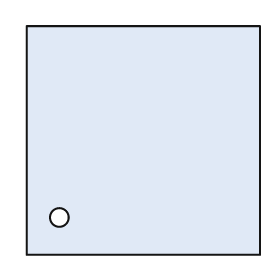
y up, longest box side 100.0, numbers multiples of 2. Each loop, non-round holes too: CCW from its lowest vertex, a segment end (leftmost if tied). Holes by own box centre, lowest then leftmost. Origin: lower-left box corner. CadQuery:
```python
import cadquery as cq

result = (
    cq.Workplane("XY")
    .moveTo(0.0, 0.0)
    .lineTo(100.0, 0.0)
    .lineTo(100.0, 98.0)
    .lineTo(0.0, 98.0)
    .close()
    .moveTo(14.0, 16.0)
    .circle(4.0)
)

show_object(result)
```